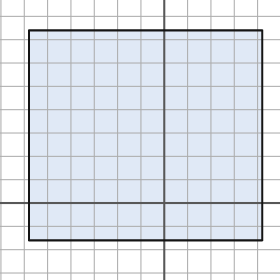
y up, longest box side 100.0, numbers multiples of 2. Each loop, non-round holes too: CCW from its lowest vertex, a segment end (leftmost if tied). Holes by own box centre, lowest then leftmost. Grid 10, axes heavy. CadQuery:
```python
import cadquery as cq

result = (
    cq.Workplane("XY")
    .moveTo(-58.0, -16.0)
    .lineTo(42.0, -16.0)
    .lineTo(42.0, 74.0)
    .lineTo(-58.0, 74.0)
    .close()
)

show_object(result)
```